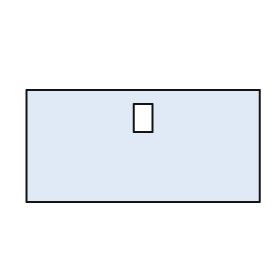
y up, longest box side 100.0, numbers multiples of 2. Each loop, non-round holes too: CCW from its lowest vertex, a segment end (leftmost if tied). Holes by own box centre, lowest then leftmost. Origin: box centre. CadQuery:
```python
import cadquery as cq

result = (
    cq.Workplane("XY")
    .moveTo(-50.0, -24.0)
    .lineTo(50.0, -24.0)
    .lineTo(50.0, 24.0)
    .lineTo(-50.0, 24.0)
    .close()
    .moveTo(-4.0, 6.0)
    .lineTo(4.0, 6.0)
    .lineTo(4.0, 18.0)
    .lineTo(-4.0, 18.0)
    .close()
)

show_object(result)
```